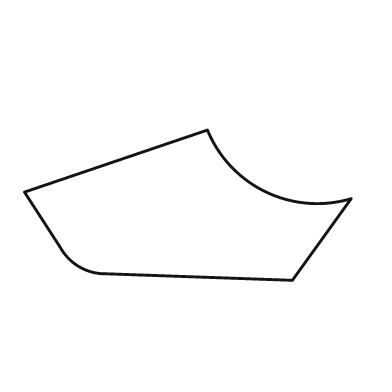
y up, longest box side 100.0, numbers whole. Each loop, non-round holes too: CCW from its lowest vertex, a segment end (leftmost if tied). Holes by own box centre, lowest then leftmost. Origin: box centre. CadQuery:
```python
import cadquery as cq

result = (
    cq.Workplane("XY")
    .moveTo(32.0, -23.0)
    .lineTo(50.0, 2.0)
    .threePointArc((24.0, 4.0), (6.0, 23.0))
    .lineTo(-50.0, 4.0)
    .lineTo(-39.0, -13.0)
    .threePointArc((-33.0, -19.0), (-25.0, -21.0))
    .close()
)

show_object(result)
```